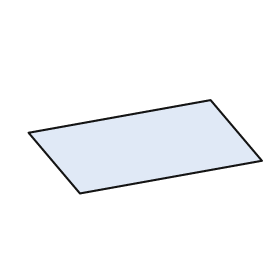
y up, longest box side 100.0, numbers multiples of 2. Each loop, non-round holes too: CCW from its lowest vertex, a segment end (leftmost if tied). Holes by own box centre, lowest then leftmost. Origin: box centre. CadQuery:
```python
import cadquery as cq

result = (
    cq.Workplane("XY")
    .moveTo(-28.0, -20.0)
    .lineTo(50.0, -6.0)
    .lineTo(28.0, 20.0)
    .lineTo(-50.0, 6.0)
    .close()
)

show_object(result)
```